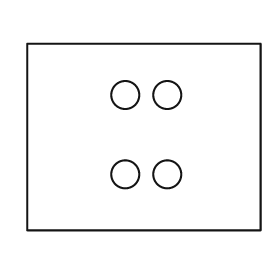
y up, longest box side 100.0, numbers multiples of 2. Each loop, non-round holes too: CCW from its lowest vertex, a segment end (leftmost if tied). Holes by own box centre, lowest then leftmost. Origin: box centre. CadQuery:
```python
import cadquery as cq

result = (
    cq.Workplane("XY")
    .moveTo(-50.0, -40.0)
    .lineTo(50.0, -40.0)
    .lineTo(50.0, 40.0)
    .lineTo(-50.0, 40.0)
    .close()
    .moveTo(-8.0, -16.0)
    .circle(6.0)
    .moveTo(10.0, -16.0)
    .circle(6.0)
    .moveTo(-8.0, 18.0)
    .circle(6.0)
    .moveTo(10.0, 18.0)
    .circle(6.0)
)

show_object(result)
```